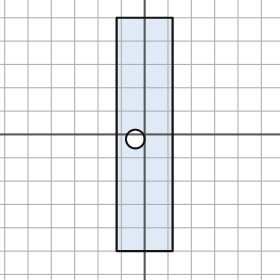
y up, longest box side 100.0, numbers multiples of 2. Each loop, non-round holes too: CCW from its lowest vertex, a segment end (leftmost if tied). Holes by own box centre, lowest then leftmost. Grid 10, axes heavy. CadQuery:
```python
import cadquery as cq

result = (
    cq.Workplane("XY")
    .moveTo(-12.0, -50.0)
    .lineTo(12.0, -50.0)
    .lineTo(12.0, 50.0)
    .lineTo(-12.0, 50.0)
    .close()
    .moveTo(-4.0, -2.0)
    .circle(4.0)
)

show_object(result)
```